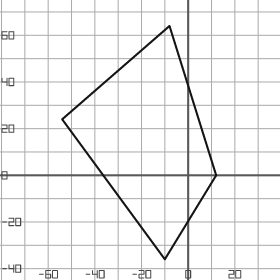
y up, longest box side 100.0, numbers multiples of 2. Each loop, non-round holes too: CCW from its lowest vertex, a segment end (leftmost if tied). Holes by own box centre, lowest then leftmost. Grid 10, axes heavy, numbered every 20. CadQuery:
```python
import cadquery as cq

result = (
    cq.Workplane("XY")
    .moveTo(-10.0, -36.0)
    .lineTo(12.0, 0.0)
    .lineTo(-8.0, 64.0)
    .lineTo(-54.0, 24.0)
    .close()
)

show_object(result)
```